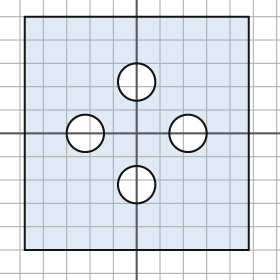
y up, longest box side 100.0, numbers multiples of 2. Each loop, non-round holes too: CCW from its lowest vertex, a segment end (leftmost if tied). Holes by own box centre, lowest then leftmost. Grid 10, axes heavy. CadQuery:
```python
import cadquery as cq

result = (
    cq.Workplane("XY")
    .moveTo(-48.0, -50.0)
    .lineTo(48.0, -50.0)
    .lineTo(48.0, 50.0)
    .lineTo(-48.0, 50.0)
    .close()
    .moveTo(0.0, -22.0)
    .circle(8.0)
    .moveTo(-22.0, 0.0)
    .circle(8.0)
    .moveTo(22.0, 0.0)
    .circle(8.0)
    .moveTo(0.0, 22.0)
    .circle(8.0)
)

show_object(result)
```